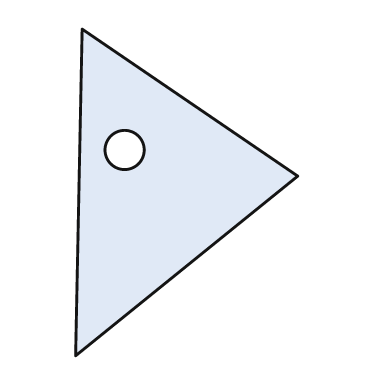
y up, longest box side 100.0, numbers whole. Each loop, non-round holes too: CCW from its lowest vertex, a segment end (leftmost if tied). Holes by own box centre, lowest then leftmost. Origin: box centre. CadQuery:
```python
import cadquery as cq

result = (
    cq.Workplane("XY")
    .moveTo(-34.0, -50.0)
    .lineTo(34.0, 5.0)
    .lineTo(-32.0, 50.0)
    .close()
    .moveTo(-19.0, 13.0)
    .circle(6.0)
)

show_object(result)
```